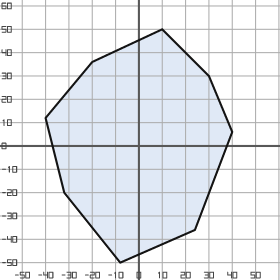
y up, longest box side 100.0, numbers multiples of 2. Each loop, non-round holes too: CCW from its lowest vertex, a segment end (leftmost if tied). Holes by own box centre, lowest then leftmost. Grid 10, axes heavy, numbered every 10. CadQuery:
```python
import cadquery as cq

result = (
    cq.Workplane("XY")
    .moveTo(-8.0, -50.0)
    .lineTo(24.0, -36.0)
    .lineTo(40.0, 6.0)
    .lineTo(30.0, 30.0)
    .lineTo(10.0, 50.0)
    .lineTo(-20.0, 36.0)
    .lineTo(-40.0, 12.0)
    .lineTo(-32.0, -20.0)
    .close()
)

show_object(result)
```